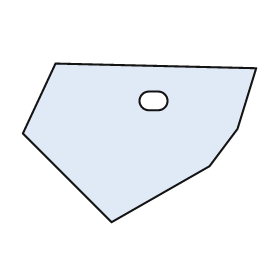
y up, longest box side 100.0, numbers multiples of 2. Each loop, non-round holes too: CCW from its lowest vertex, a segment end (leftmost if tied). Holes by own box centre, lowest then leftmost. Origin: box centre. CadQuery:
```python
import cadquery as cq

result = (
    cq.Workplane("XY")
    .moveTo(-12.0, -34.0)
    .lineTo(30.0, -10.0)
    .lineTo(42.0, 6.0)
    .lineTo(50.0, 32.0)
    .lineTo(-36.0, 34.0)
    .lineTo(-50.0, 4.0)
    .close()
    .moveTo(4.0, 14.0)
    .lineTo(8.0, 14.0)
    .threePointArc((12.0, 18.0), (8.0, 22.0))
    .lineTo(4.0, 22.0)
    .threePointArc((0.0, 18.0), (4.0, 14.0))
    .close()
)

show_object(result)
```